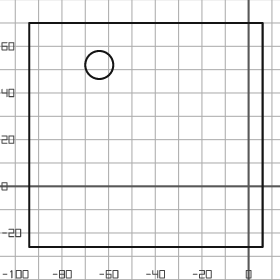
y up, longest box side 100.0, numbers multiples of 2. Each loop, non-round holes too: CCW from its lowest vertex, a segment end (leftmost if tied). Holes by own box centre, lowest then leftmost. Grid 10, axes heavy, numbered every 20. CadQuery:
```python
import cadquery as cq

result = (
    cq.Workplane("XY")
    .moveTo(-94.0, -26.0)
    .lineTo(6.0, -26.0)
    .lineTo(6.0, 70.0)
    .lineTo(-94.0, 70.0)
    .close()
    .moveTo(-64.0, 52.0)
    .circle(6.0)
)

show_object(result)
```